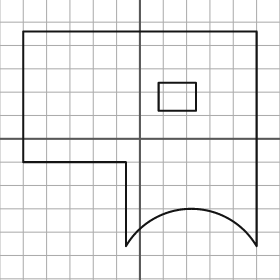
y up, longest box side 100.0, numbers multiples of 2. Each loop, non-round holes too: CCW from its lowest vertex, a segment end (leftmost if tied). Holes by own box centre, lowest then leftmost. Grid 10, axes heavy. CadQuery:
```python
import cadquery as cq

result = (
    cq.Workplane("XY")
    .moveTo(-6.0, -46.0)
    .threePointArc((22.0, -30.0), (50.0, -46.0))
    .lineTo(50.0, 46.0)
    .lineTo(-50.0, 46.0)
    .lineTo(-50.0, -10.0)
    .lineTo(-6.0, -10.0)
    .close()
    .moveTo(8.0, 12.0)
    .lineTo(24.0, 12.0)
    .lineTo(24.0, 24.0)
    .lineTo(8.0, 24.0)
    .close()
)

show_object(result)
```